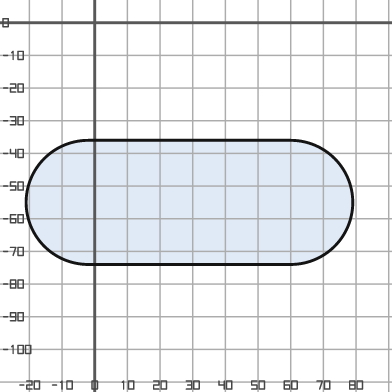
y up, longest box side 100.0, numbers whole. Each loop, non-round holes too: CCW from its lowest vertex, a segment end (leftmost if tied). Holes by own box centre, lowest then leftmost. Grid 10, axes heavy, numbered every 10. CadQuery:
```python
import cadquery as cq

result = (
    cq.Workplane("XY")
    .moveTo(-2.0, -74.0)
    .lineTo(60.0, -74.0)
    .threePointArc((79.0, -55.0), (60.0, -36.0))
    .lineTo(-2.0, -36.0)
    .threePointArc((-21.0, -55.0), (-2.0, -74.0))
    .close()
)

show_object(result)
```